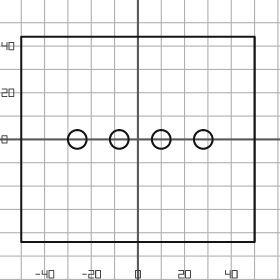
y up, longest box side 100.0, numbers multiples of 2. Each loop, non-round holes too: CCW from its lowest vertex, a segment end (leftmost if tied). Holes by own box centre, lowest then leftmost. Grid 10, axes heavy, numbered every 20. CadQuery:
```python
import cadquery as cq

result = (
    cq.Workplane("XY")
    .moveTo(-50.0, -44.0)
    .lineTo(50.0, -44.0)
    .lineTo(50.0, 44.0)
    .lineTo(-50.0, 44.0)
    .close()
    .moveTo(-26.0, 0.0)
    .circle(4.0)
    .moveTo(-8.0, 0.0)
    .circle(4.0)
    .moveTo(10.0, 0.0)
    .circle(4.0)
    .moveTo(28.0, 0.0)
    .circle(4.0)
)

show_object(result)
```